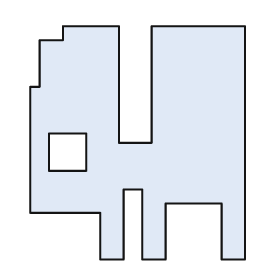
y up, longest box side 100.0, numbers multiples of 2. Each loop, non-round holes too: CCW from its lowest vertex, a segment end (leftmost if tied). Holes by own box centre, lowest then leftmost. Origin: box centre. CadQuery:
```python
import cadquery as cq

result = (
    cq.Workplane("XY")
    .moveTo(-16.0, -50.0)
    .lineTo(-6.0, -50.0)
    .lineTo(-6.0, -20.0)
    .lineTo(2.0, -20.0)
    .lineTo(2.0, -50.0)
    .lineTo(12.0, -50.0)
    .lineTo(12.0, -26.0)
    .lineTo(36.0, -26.0)
    .lineTo(36.0, -50.0)
    .lineTo(46.0, -50.0)
    .lineTo(46.0, 50.0)
    .lineTo(6.0, 50.0)
    .lineTo(6.0, 0.0)
    .lineTo(-8.0, 0.0)
    .lineTo(-8.0, 50.0)
    .lineTo(-32.0, 50.0)
    .lineTo(-32.0, 44.0)
    .lineTo(-42.0, 44.0)
    .lineTo(-42.0, 24.0)
    .lineTo(-46.0, 24.0)
    .lineTo(-46.0, -30.0)
    .lineTo(-16.0, -30.0)
    .close()
    .moveTo(-38.0, -12.0)
    .lineTo(-22.0, -12.0)
    .lineTo(-22.0, 4.0)
    .lineTo(-38.0, 4.0)
    .close()
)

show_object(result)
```